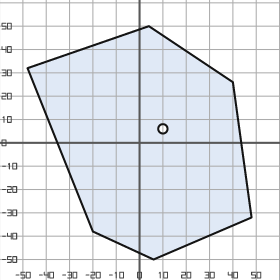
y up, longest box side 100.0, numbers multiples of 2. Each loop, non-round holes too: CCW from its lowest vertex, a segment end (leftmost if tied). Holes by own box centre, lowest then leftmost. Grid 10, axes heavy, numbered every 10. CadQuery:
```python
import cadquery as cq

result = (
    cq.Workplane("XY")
    .moveTo(6.0, -50.0)
    .lineTo(48.0, -32.0)
    .lineTo(40.0, 26.0)
    .lineTo(4.0, 50.0)
    .lineTo(-48.0, 32.0)
    .lineTo(-20.0, -38.0)
    .close()
    .moveTo(10.0, 6.0)
    .circle(2.0)
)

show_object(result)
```